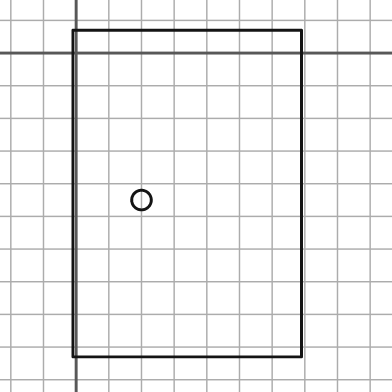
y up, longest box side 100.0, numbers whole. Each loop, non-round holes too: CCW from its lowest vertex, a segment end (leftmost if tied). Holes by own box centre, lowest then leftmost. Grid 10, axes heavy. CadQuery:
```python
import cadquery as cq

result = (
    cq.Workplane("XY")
    .moveTo(-1.0, -93.0)
    .lineTo(69.0, -93.0)
    .lineTo(69.0, 7.0)
    .lineTo(-1.0, 7.0)
    .close()
    .moveTo(20.0, -45.0)
    .circle(3.0)
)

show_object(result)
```